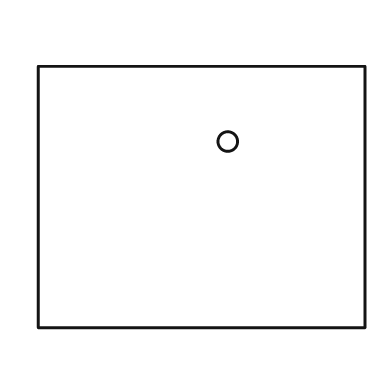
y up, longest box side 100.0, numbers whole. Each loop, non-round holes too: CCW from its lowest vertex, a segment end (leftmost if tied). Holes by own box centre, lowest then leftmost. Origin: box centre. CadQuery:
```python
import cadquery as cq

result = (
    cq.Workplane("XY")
    .moveTo(-50.0, -40.0)
    .lineTo(50.0, -40.0)
    .lineTo(50.0, 40.0)
    .lineTo(-50.0, 40.0)
    .close()
    .moveTo(8.0, 17.0)
    .circle(3.0)
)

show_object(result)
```